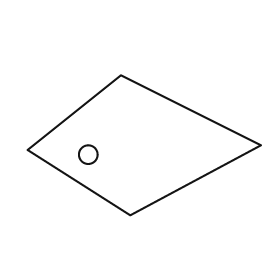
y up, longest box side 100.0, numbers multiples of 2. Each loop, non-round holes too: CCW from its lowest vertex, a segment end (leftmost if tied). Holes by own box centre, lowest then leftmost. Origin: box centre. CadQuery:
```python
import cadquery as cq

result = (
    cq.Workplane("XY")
    .moveTo(-6.0, -30.0)
    .lineTo(50.0, 0.0)
    .lineTo(-10.0, 30.0)
    .lineTo(-50.0, -2.0)
    .close()
    .moveTo(-24.0, -4.0)
    .circle(4.0)
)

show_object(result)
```